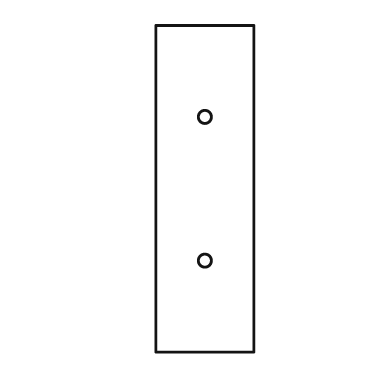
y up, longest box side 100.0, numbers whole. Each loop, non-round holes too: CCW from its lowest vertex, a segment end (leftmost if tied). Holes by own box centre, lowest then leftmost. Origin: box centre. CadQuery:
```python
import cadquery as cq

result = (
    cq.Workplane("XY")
    .moveTo(-15.0, -50.0)
    .lineTo(15.0, -50.0)
    .lineTo(15.0, 50.0)
    .lineTo(-15.0, 50.0)
    .close()
    .moveTo(0.0, -22.0)
    .circle(2.0)
    .moveTo(0.0, 22.0)
    .circle(2.0)
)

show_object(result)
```